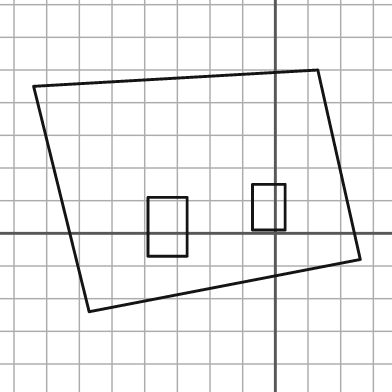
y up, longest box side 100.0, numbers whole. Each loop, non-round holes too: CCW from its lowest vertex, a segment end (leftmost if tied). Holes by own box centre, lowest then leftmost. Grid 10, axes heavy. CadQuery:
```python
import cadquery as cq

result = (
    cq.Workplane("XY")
    .moveTo(-57.0, -24.0)
    .lineTo(26.0, -8.0)
    .lineTo(13.0, 50.0)
    .lineTo(-74.0, 45.0)
    .close()
    .moveTo(-39.0, -7.0)
    .lineTo(-27.0, -7.0)
    .lineTo(-27.0, 11.0)
    .lineTo(-39.0, 11.0)
    .close()
    .moveTo(-7.0, 1.0)
    .lineTo(3.0, 1.0)
    .lineTo(3.0, 15.0)
    .lineTo(-7.0, 15.0)
    .close()
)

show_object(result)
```